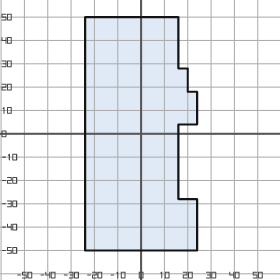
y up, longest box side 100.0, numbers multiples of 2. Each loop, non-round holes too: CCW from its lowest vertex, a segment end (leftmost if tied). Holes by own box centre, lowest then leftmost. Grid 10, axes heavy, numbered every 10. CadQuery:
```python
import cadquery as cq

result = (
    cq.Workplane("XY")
    .moveTo(-24.0, -50.0)
    .lineTo(24.0, -50.0)
    .lineTo(24.0, -28.0)
    .lineTo(16.0, -28.0)
    .lineTo(16.0, 4.0)
    .lineTo(24.0, 4.0)
    .lineTo(24.0, 18.0)
    .lineTo(20.0, 18.0)
    .lineTo(20.0, 28.0)
    .lineTo(16.0, 28.0)
    .lineTo(16.0, 50.0)
    .lineTo(-24.0, 50.0)
    .close()
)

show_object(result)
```